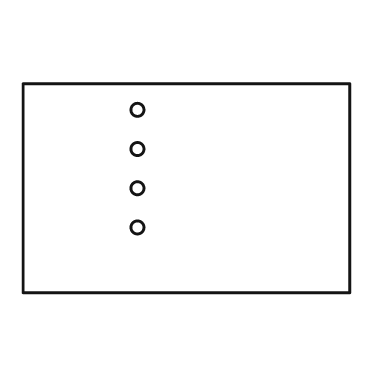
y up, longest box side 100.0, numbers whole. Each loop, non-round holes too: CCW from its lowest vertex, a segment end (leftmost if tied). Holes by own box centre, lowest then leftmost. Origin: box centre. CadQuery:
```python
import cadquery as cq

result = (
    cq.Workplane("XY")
    .moveTo(-50.0, -32.0)
    .lineTo(50.0, -32.0)
    .lineTo(50.0, 32.0)
    .lineTo(-50.0, 32.0)
    .close()
    .moveTo(-15.0, -12.0)
    .circle(2.0)
    .moveTo(-15.0, 0.0)
    .circle(2.0)
    .moveTo(-15.0, 12.0)
    .circle(2.0)
    .moveTo(-15.0, 24.0)
    .circle(2.0)
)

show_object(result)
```